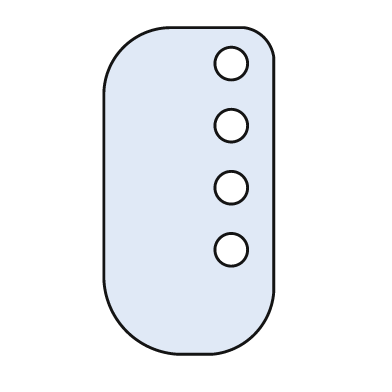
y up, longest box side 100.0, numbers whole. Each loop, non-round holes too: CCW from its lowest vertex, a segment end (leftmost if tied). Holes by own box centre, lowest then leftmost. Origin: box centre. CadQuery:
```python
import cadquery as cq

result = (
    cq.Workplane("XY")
    .moveTo(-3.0, -50.0)
    .lineTo(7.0, -50.0)
    .threePointArc((20.0, -44.0), (26.0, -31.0))
    .lineTo(26.0, 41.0)
    .threePointArc((23.0, 47.0), (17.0, 50.0))
    .lineTo(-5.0, 50.0)
    .threePointArc((-20.0, 44.0), (-26.0, 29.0))
    .lineTo(-26.0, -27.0)
    .threePointArc((-19.0, -43.0), (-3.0, -50.0))
    .close()
    .moveTo(13.0, -18.0)
    .circle(5.0)
    .moveTo(13.0, 1.0)
    .circle(5.0)
    .moveTo(13.0, 20.0)
    .circle(5.0)
    .moveTo(13.0, 39.0)
    .circle(5.0)
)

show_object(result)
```